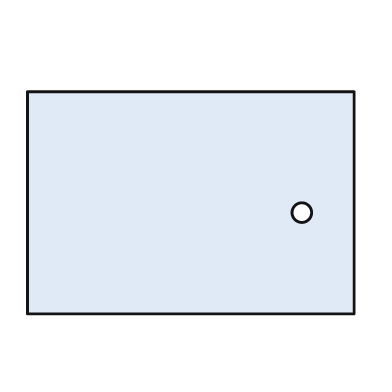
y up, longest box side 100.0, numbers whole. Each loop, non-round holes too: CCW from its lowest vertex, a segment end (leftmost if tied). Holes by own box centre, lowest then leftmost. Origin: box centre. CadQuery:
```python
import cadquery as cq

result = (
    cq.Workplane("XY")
    .moveTo(-50.0, -34.0)
    .lineTo(50.0, -34.0)
    .lineTo(50.0, 34.0)
    .lineTo(-50.0, 34.0)
    .close()
    .moveTo(34.0, -3.0)
    .circle(3.0)
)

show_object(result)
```